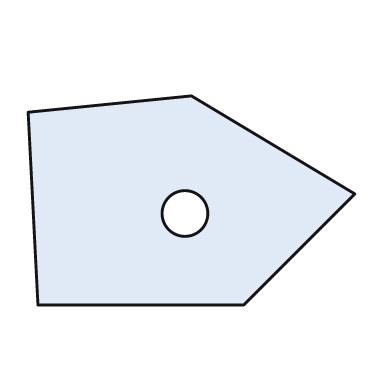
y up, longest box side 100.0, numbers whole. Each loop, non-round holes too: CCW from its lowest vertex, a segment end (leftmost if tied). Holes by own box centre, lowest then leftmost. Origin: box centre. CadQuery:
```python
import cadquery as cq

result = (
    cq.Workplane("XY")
    .moveTo(-47.0, -32.0)
    .lineTo(16.0, -32.0)
    .lineTo(50.0, 2.0)
    .lineTo(0.0, 32.0)
    .lineTo(-50.0, 27.0)
    .close()
    .moveTo(-2.0, -4.0)
    .circle(7.0)
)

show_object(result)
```